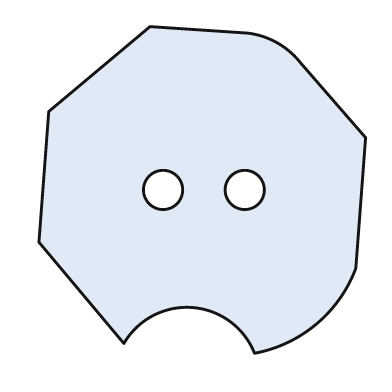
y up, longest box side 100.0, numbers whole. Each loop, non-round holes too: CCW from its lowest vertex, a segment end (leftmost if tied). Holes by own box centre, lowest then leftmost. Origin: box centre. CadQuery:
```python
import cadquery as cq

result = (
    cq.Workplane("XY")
    .moveTo(16.0, -50.0)
    .threePointArc((35.0, -41.0), (47.0, -24.0))
    .lineTo(50.0, 16.0)
    .lineTo(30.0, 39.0)
    .threePointArc((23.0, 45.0), (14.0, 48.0))
    .lineTo(-16.0, 50.0)
    .lineTo(-47.0, 24.0)
    .lineTo(-50.0, -16.0)
    .lineTo(-24.0, -47.0)
    .threePointArc((-3.0, -36.0), (16.0, -50.0))
    .close()
    .moveTo(-12.0, 0.0)
    .circle(6.0)
    .moveTo(13.0, 0.0)
    .circle(6.0)
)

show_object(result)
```